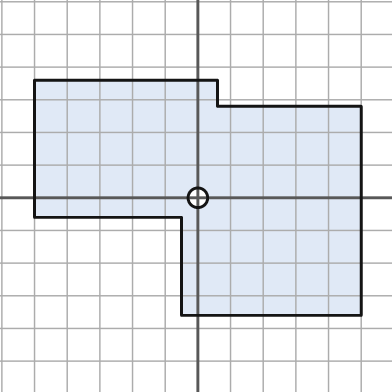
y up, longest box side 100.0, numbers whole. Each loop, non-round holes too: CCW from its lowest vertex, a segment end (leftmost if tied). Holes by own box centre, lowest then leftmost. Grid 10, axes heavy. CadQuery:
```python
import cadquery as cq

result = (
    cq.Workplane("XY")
    .moveTo(-5.0, -36.0)
    .lineTo(50.0, -36.0)
    .lineTo(50.0, 28.0)
    .lineTo(6.0, 28.0)
    .lineTo(6.0, 36.0)
    .lineTo(-50.0, 36.0)
    .lineTo(-50.0, -6.0)
    .lineTo(-5.0, -6.0)
    .close()
    .moveTo(0.0, 0.0)
    .circle(3.0)
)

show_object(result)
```